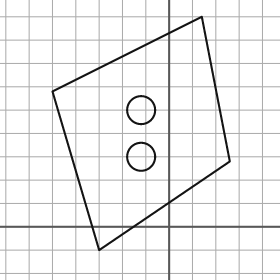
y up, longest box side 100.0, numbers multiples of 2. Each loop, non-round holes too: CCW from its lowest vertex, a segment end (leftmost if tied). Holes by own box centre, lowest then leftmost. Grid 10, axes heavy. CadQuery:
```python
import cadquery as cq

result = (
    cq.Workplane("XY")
    .moveTo(-30.0, -10.0)
    .lineTo(26.0, 28.0)
    .lineTo(14.0, 90.0)
    .lineTo(-50.0, 58.0)
    .close()
    .moveTo(-12.0, 30.0)
    .circle(6.0)
    .moveTo(-12.0, 50.0)
    .circle(6.0)
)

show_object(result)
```